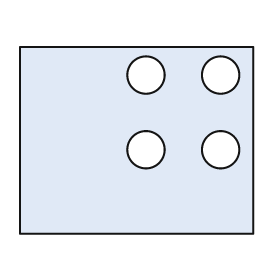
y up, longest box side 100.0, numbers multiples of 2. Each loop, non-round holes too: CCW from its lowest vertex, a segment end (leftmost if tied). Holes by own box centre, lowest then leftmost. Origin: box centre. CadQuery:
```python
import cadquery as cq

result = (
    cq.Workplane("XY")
    .moveTo(-50.0, -40.0)
    .lineTo(50.0, -40.0)
    .lineTo(50.0, 40.0)
    .lineTo(-50.0, 40.0)
    .close()
    .moveTo(4.0, -4.0)
    .circle(8.0)
    .moveTo(36.0, -4.0)
    .circle(8.0)
    .moveTo(4.0, 28.0)
    .circle(8.0)
    .moveTo(36.0, 28.0)
    .circle(8.0)
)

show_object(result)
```